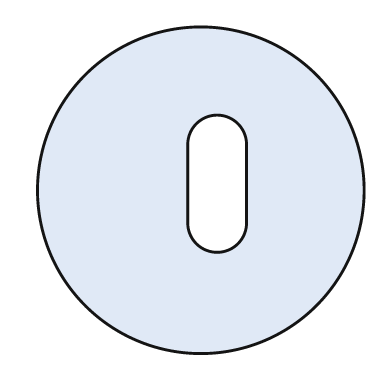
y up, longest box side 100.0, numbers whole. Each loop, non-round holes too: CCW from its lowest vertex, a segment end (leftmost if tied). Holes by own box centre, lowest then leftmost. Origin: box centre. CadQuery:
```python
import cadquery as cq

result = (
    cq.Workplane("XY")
    .moveTo(0.0, 0.0)
    .circle(50.0)
    .moveTo(-4.0, -10.0)
    .threePointArc((5.0, -19.0), (14.0, -10.0))
    .lineTo(14.0, 14.0)
    .threePointArc((5.0, 23.0), (-4.0, 14.0))
    .close()
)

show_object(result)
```